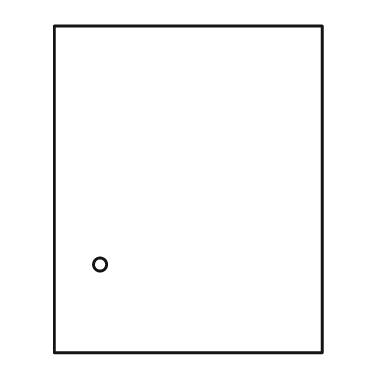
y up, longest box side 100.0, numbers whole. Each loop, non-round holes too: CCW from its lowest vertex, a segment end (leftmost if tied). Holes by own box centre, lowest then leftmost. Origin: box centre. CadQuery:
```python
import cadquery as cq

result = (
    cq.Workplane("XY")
    .moveTo(-41.0, -50.0)
    .lineTo(41.0, -50.0)
    .lineTo(41.0, 50.0)
    .lineTo(-41.0, 50.0)
    .close()
    .moveTo(-27.0, -23.0)
    .circle(2.0)
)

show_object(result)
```